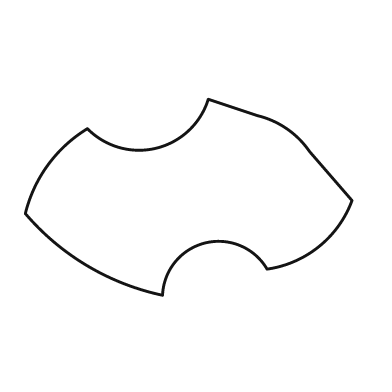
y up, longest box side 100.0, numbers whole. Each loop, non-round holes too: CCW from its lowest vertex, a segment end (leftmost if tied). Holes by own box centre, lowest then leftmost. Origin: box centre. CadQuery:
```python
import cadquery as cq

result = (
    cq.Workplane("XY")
    .moveTo(-8.0, -30.0)
    .threePointArc((5.0, -14.0), (24.0, -22.0))
    .threePointArc((40.0, -15.0), (50.0, -1.0))
    .lineTo(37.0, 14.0)
    .threePointArc((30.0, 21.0), (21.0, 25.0))
    .lineTo(6.0, 30.0)
    .threePointArc((-10.0, 15.0), (-31.0, 21.0))
    .threePointArc((-43.0, 10.0), (-50.0, -5.0))
    .threePointArc((-31.0, -21.0), (-8.0, -30.0))
    .close()
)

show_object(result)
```